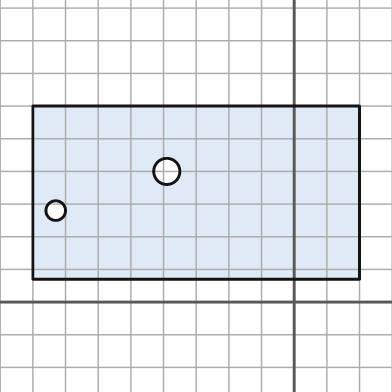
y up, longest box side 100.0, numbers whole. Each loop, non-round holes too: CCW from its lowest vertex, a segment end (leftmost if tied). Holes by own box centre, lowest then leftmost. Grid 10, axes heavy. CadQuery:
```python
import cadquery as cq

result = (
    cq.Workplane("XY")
    .moveTo(-80.0, 7.0)
    .lineTo(20.0, 7.0)
    .lineTo(20.0, 60.0)
    .lineTo(-80.0, 60.0)
    .close()
    .moveTo(-73.0, 28.0)
    .circle(3.0)
    .moveTo(-39.0, 40.0)
    .circle(4.0)
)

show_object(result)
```